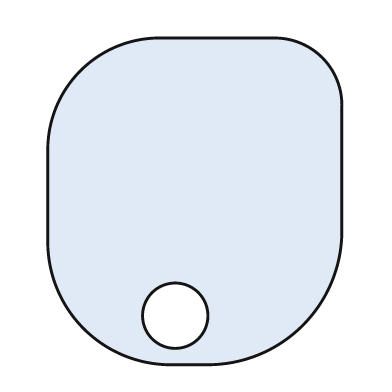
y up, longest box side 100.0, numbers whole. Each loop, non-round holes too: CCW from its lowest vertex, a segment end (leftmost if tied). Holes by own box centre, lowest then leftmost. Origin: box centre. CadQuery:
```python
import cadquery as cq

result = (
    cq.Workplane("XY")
    .moveTo(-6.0, -50.0)
    .lineTo(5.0, -50.0)
    .threePointArc((33.0, -38.0), (45.0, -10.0))
    .lineTo(45.0, 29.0)
    .threePointArc((39.0, 44.0), (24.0, 50.0))
    .lineTo(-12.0, 50.0)
    .threePointArc((-35.0, 40.0), (-45.0, 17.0))
    .lineTo(-45.0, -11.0)
    .threePointArc((-34.0, -39.0), (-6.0, -50.0))
    .close()
    .moveTo(-6.0, -35.0)
    .circle(10.0)
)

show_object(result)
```